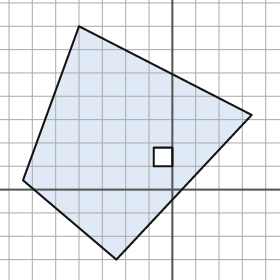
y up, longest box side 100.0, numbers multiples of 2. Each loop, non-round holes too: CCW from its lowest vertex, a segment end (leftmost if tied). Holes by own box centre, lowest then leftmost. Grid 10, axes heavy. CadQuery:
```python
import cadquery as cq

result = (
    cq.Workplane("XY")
    .moveTo(-24.0, -30.0)
    .lineTo(34.0, 32.0)
    .lineTo(-40.0, 70.0)
    .lineTo(-64.0, 4.0)
    .close()
    .moveTo(-8.0, 10.0)
    .lineTo(0.0, 10.0)
    .lineTo(0.0, 18.0)
    .lineTo(-8.0, 18.0)
    .close()
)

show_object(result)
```